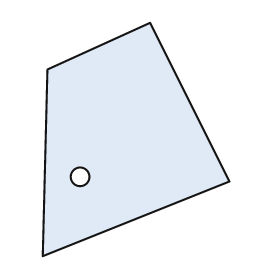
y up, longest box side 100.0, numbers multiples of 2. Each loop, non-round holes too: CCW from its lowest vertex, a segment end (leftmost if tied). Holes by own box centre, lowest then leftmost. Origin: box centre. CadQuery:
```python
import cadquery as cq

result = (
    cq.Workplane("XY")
    .moveTo(-40.0, -50.0)
    .lineTo(40.0, -18.0)
    .lineTo(6.0, 50.0)
    .lineTo(-38.0, 30.0)
    .close()
    .moveTo(-24.0, -16.0)
    .circle(4.0)
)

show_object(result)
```